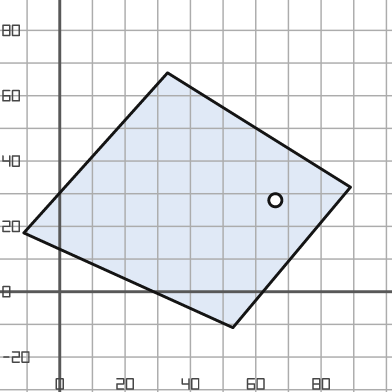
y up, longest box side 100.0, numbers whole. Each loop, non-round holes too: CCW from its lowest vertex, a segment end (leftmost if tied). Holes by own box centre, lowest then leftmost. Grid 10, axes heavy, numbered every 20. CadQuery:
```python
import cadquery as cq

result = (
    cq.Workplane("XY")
    .moveTo(53.0, -11.0)
    .lineTo(89.0, 32.0)
    .lineTo(33.0, 67.0)
    .lineTo(-11.0, 18.0)
    .close()
    .moveTo(66.0, 28.0)
    .circle(2.0)
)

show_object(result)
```